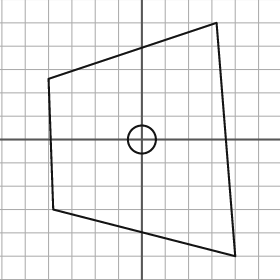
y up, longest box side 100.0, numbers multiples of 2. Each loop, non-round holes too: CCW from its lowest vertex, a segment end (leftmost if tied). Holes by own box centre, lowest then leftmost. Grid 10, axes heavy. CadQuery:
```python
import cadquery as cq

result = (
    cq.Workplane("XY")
    .moveTo(40.0, -50.0)
    .lineTo(32.0, 50.0)
    .lineTo(-40.0, 26.0)
    .lineTo(-38.0, -30.0)
    .close()
    .moveTo(0.0, 0.0)
    .circle(6.0)
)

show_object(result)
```